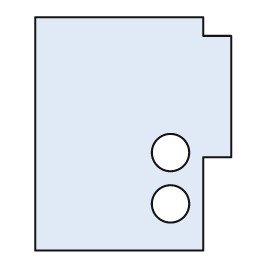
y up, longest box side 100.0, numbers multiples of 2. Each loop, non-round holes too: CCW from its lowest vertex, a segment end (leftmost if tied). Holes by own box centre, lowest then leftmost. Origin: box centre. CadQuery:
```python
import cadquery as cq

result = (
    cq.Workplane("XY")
    .moveTo(-42.0, -50.0)
    .lineTo(30.0, -50.0)
    .lineTo(30.0, -10.0)
    .lineTo(42.0, -10.0)
    .lineTo(42.0, 42.0)
    .lineTo(30.0, 42.0)
    .lineTo(30.0, 50.0)
    .lineTo(-42.0, 50.0)
    .close()
    .moveTo(16.0, -30.0)
    .circle(8.0)
    .moveTo(16.0, -8.0)
    .circle(8.0)
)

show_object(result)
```